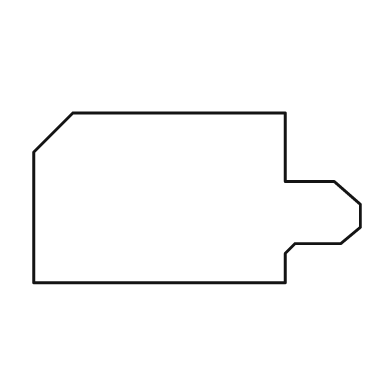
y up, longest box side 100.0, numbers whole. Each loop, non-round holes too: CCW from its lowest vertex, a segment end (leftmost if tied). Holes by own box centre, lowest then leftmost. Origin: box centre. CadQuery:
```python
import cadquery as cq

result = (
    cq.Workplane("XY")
    .moveTo(-50.0, -26.0)
    .lineTo(27.0, -26.0)
    .lineTo(27.0, -17.0)
    .lineTo(30.0, -14.0)
    .lineTo(44.0, -14.0)
    .lineTo(50.0, -9.0)
    .lineTo(50.0, -2.0)
    .lineTo(42.0, 5.0)
    .lineTo(27.0, 5.0)
    .lineTo(27.0, 26.0)
    .lineTo(-38.0, 26.0)
    .lineTo(-50.0, 14.0)
    .close()
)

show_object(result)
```